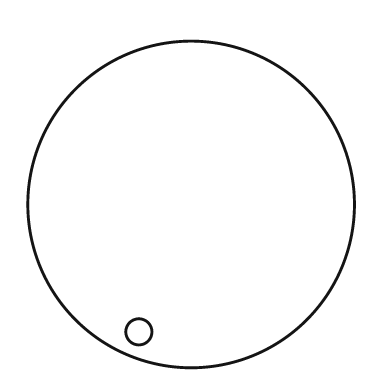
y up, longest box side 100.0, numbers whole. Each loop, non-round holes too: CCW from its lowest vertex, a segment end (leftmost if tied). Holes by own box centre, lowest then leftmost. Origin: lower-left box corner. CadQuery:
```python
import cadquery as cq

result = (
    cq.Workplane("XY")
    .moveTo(50.0, 50.0)
    .circle(50.0)
    .moveTo(34.0, 11.0)
    .circle(4.0)
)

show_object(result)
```